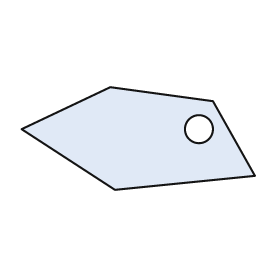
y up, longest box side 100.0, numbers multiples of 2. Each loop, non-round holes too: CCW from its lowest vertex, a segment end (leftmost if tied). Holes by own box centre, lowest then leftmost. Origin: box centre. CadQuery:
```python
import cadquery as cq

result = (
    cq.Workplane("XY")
    .moveTo(-10.0, -22.0)
    .lineTo(50.0, -16.0)
    .lineTo(32.0, 16.0)
    .lineTo(-12.0, 22.0)
    .lineTo(-50.0, 4.0)
    .close()
    .moveTo(26.0, 4.0)
    .circle(6.0)
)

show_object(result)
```